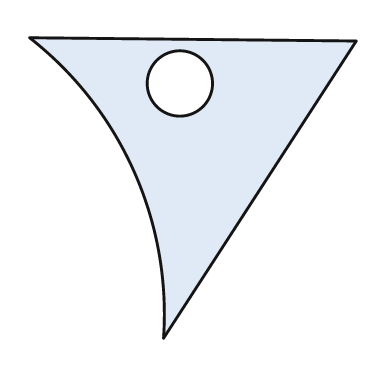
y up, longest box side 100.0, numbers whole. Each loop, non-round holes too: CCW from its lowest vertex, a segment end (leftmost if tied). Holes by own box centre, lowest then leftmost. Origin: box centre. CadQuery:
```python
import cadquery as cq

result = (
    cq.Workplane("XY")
    .moveTo(-9.0, -46.0)
    .lineTo(50.0, 45.0)
    .lineTo(-50.0, 46.0)
    .threePointArc((-18.0, 5.0), (-9.0, -46.0))
    .close()
    .moveTo(-4.0, 32.0)
    .circle(10.0)
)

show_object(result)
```